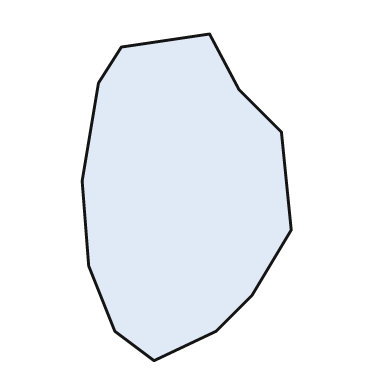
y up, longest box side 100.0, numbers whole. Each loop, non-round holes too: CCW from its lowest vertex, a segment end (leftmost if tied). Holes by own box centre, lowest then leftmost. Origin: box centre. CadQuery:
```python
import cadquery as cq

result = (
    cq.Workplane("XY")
    .moveTo(-10.0, -50.0)
    .lineTo(9.0, -41.0)
    .lineTo(20.0, -30.0)
    .lineTo(32.0, -10.0)
    .lineTo(29.0, 20.0)
    .lineTo(16.0, 33.0)
    .lineTo(7.0, 50.0)
    .lineTo(-20.0, 46.0)
    .lineTo(-27.0, 35.0)
    .lineTo(-32.0, 5.0)
    .lineTo(-30.0, -21.0)
    .lineTo(-22.0, -41.0)
    .close()
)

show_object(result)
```